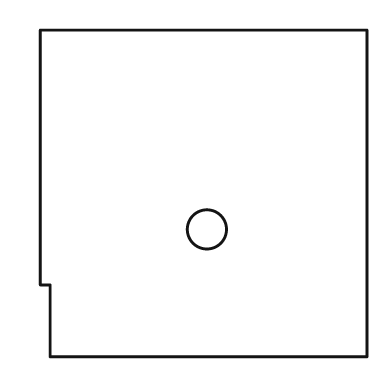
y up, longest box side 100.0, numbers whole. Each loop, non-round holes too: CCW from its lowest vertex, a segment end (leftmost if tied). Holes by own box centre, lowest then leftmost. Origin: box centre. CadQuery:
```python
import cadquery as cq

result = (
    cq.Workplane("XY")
    .moveTo(-47.0, -50.0)
    .lineTo(50.0, -50.0)
    .lineTo(50.0, 50.0)
    .lineTo(-50.0, 50.0)
    .lineTo(-50.0, -28.0)
    .lineTo(-47.0, -28.0)
    .close()
    .moveTo(1.0, -11.0)
    .circle(6.0)
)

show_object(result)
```